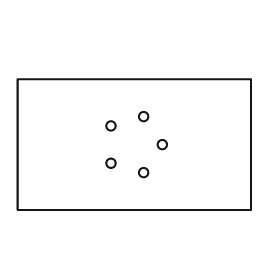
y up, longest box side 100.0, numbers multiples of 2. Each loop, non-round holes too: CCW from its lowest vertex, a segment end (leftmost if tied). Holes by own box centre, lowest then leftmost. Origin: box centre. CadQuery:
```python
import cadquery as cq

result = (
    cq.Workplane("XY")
    .moveTo(-50.0, -28.0)
    .lineTo(50.0, -28.0)
    .lineTo(50.0, 28.0)
    .lineTo(-50.0, 28.0)
    .close()
    .moveTo(4.0, -12.0)
    .circle(2.0)
    .moveTo(-10.0, -8.0)
    .circle(2.0)
    .moveTo(12.0, 0.0)
    .circle(2.0)
    .moveTo(-10.0, 8.0)
    .circle(2.0)
    .moveTo(4.0, 12.0)
    .circle(2.0)
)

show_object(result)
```